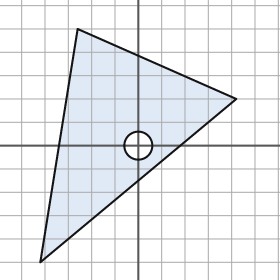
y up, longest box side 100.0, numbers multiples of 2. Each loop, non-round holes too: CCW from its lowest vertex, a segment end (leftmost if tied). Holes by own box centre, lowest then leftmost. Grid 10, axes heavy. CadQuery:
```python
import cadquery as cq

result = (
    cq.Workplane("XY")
    .moveTo(-42.0, -50.0)
    .lineTo(42.0, 20.0)
    .lineTo(-26.0, 50.0)
    .close()
    .moveTo(0.0, 0.0)
    .circle(6.0)
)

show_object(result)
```